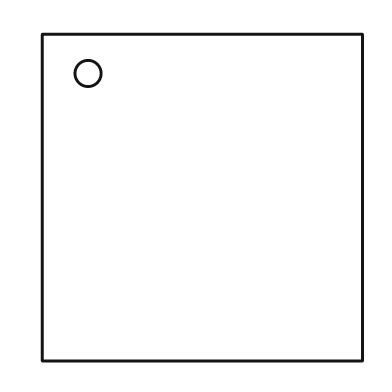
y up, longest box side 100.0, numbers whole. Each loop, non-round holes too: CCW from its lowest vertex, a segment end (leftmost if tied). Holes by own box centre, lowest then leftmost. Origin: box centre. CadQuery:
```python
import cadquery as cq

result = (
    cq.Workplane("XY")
    .moveTo(-49.0, -50.0)
    .lineTo(49.0, -50.0)
    .lineTo(49.0, 50.0)
    .lineTo(-49.0, 50.0)
    .close()
    .moveTo(-35.0, 38.0)
    .circle(4.0)
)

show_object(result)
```